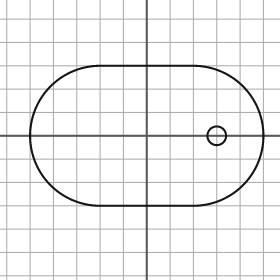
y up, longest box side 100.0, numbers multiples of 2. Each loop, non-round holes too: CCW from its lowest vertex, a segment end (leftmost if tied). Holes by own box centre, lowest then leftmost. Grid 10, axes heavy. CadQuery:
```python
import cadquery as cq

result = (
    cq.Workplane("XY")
    .moveTo(-20.0, -30.0)
    .lineTo(20.0, -30.0)
    .threePointArc((50.0, 0.0), (20.0, 30.0))
    .lineTo(-20.0, 30.0)
    .threePointArc((-50.0, 0.0), (-20.0, -30.0))
    .close()
    .moveTo(30.0, 0.0)
    .circle(4.0)
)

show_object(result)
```